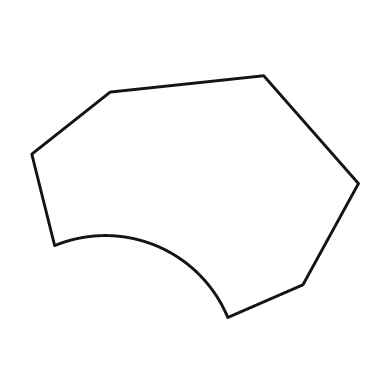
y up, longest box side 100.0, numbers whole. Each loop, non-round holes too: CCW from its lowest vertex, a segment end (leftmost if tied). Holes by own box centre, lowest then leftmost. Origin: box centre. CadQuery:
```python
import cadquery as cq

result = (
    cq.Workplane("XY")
    .moveTo(10.0, -37.0)
    .lineTo(33.0, -27.0)
    .lineTo(50.0, 4.0)
    .lineTo(21.0, 37.0)
    .lineTo(-26.0, 32.0)
    .lineTo(-50.0, 13.0)
    .lineTo(-43.0, -15.0)
    .threePointArc((-12.0, -15.0), (10.0, -37.0))
    .close()
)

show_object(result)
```